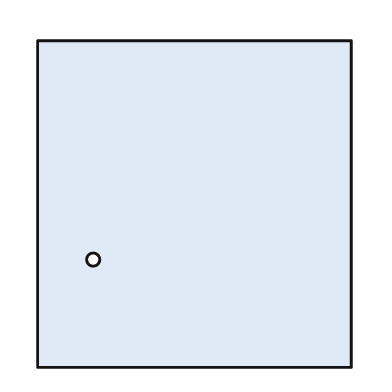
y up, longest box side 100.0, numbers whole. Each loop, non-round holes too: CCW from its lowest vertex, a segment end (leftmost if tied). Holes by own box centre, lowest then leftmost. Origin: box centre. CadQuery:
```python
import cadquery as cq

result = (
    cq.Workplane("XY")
    .moveTo(-48.0, -50.0)
    .lineTo(48.0, -50.0)
    .lineTo(48.0, 50.0)
    .lineTo(-48.0, 50.0)
    .close()
    .moveTo(-31.0, -17.0)
    .circle(2.0)
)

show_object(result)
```